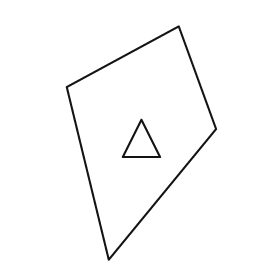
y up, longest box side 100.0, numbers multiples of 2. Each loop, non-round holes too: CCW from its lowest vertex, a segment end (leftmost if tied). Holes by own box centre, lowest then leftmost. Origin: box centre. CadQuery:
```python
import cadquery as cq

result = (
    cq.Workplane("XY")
    .moveTo(-14.0, -50.0)
    .lineTo(32.0, 6.0)
    .lineTo(16.0, 50.0)
    .lineTo(-32.0, 24.0)
    .close()
    .moveTo(-8.0, -6.0)
    .lineTo(8.0, -6.0)
    .lineTo(0.0, 10.0)
    .close()
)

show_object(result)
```